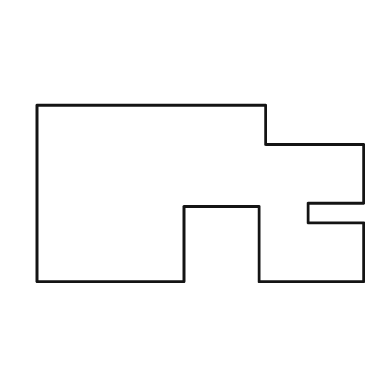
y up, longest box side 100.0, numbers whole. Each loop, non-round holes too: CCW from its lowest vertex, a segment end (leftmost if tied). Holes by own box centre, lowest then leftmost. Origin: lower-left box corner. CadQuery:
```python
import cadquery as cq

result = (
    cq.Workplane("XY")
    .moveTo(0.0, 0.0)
    .lineTo(45.0, 0.0)
    .lineTo(45.0, 23.0)
    .lineTo(68.0, 23.0)
    .lineTo(68.0, 0.0)
    .lineTo(100.0, 0.0)
    .lineTo(100.0, 18.0)
    .lineTo(83.0, 18.0)
    .lineTo(83.0, 24.0)
    .lineTo(100.0, 24.0)
    .lineTo(100.0, 42.0)
    .lineTo(70.0, 42.0)
    .lineTo(70.0, 54.0)
    .lineTo(0.0, 54.0)
    .close()
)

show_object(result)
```